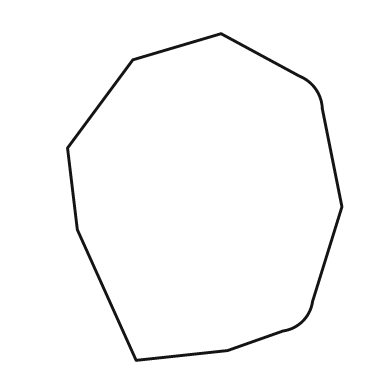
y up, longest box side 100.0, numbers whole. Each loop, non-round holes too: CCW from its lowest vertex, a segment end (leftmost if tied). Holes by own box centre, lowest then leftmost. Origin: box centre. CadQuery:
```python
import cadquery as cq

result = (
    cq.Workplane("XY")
    .moveTo(-21.0, -50.0)
    .lineTo(7.0, -47.0)
    .lineTo(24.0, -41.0)
    .threePointArc((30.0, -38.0), (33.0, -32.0))
    .lineTo(42.0, -3.0)
    .lineTo(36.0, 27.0)
    .threePointArc((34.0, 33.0), (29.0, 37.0))
    .lineTo(5.0, 50.0)
    .lineTo(-22.0, 42.0)
    .lineTo(-42.0, 15.0)
    .lineTo(-39.0, -10.0)
    .close()
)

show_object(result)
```